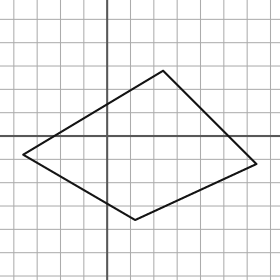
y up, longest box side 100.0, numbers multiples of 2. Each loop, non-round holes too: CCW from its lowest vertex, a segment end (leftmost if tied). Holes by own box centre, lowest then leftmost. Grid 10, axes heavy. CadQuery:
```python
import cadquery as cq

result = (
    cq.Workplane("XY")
    .moveTo(12.0, -36.0)
    .lineTo(64.0, -12.0)
    .lineTo(24.0, 28.0)
    .lineTo(-36.0, -8.0)
    .close()
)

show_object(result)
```